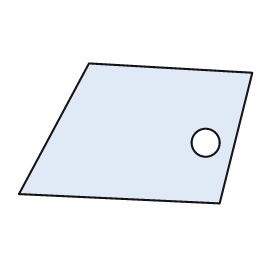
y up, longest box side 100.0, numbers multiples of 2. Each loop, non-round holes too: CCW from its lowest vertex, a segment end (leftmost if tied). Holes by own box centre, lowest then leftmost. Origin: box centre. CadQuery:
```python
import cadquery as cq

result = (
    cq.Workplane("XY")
    .moveTo(36.0, -30.0)
    .lineTo(50.0, 26.0)
    .lineTo(-20.0, 30.0)
    .lineTo(-50.0, -26.0)
    .close()
    .moveTo(30.0, -4.0)
    .circle(6.0)
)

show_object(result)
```